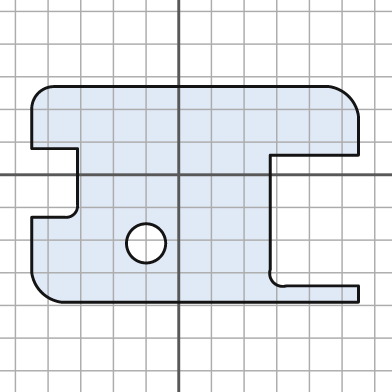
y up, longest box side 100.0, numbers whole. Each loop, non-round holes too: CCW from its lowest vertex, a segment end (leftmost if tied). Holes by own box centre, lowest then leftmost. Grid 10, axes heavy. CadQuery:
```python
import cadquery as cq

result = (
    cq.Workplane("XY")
    .moveTo(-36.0, -39.0)
    .lineTo(55.0, -39.0)
    .lineTo(55.0, -34.0)
    .lineTo(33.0, -34.0)
    .threePointArc((29.0, -33.0), (28.0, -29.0))
    .lineTo(28.0, 6.0)
    .lineTo(55.0, 6.0)
    .lineTo(55.0, 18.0)
    .threePointArc((52.0, 24.0), (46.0, 27.0))
    .lineTo(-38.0, 27.0)
    .threePointArc((-43.0, 25.0), (-45.0, 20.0))
    .lineTo(-45.0, 8.0)
    .lineTo(-31.0, 8.0)
    .lineTo(-31.0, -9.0)
    .threePointArc((-32.0, -12.0), (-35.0, -13.0))
    .lineTo(-45.0, -13.0)
    .lineTo(-45.0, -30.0)
    .threePointArc((-42.0, -36.0), (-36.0, -39.0))
    .close()
    .moveTo(-10.0, -21.0)
    .circle(6.0)
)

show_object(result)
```